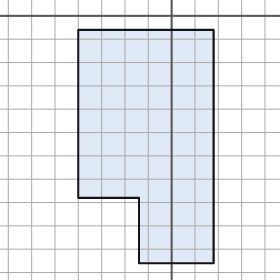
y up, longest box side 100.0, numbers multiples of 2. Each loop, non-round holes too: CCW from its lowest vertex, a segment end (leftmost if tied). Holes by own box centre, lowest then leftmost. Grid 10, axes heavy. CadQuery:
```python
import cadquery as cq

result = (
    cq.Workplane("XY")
    .moveTo(-14.0, -106.0)
    .lineTo(18.0, -106.0)
    .lineTo(18.0, -6.0)
    .lineTo(-40.0, -6.0)
    .lineTo(-40.0, -78.0)
    .lineTo(-14.0, -78.0)
    .close()
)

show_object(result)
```